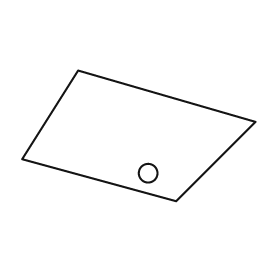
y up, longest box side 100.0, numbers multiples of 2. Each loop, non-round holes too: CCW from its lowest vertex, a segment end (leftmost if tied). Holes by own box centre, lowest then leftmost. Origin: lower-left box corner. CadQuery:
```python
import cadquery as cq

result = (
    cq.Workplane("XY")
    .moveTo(66.0, 0.0)
    .lineTo(100.0, 34.0)
    .lineTo(24.0, 56.0)
    .lineTo(0.0, 18.0)
    .close()
    .moveTo(54.0, 12.0)
    .circle(4.0)
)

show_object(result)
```